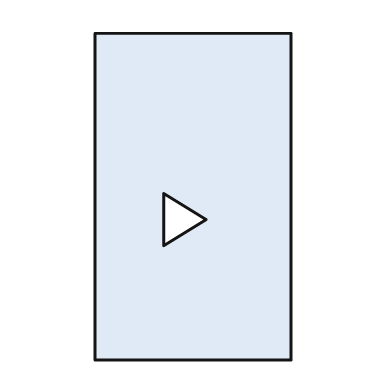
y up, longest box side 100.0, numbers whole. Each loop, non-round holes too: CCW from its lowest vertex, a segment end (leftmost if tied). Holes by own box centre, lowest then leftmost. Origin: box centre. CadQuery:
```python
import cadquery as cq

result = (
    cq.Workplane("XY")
    .moveTo(-30.0, -50.0)
    .lineTo(30.0, -50.0)
    .lineTo(30.0, 50.0)
    .lineTo(-30.0, 50.0)
    .close()
    .moveTo(-9.0, -15.0)
    .lineTo(4.0, -7.0)
    .lineTo(-9.0, 1.0)
    .close()
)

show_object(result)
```